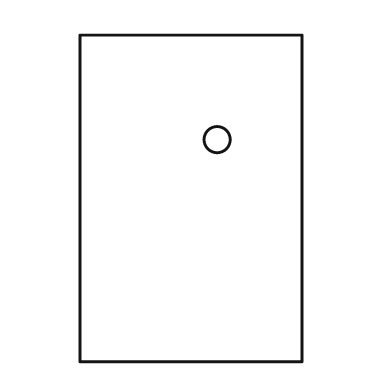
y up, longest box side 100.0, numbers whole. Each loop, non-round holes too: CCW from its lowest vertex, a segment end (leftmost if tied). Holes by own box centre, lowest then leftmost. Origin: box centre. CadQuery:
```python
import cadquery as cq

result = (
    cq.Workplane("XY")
    .moveTo(-34.0, -50.0)
    .lineTo(34.0, -50.0)
    .lineTo(34.0, 50.0)
    .lineTo(-34.0, 50.0)
    .close()
    .moveTo(8.0, 18.0)
    .circle(4.0)
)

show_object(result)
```